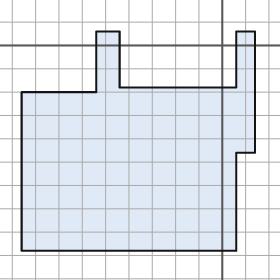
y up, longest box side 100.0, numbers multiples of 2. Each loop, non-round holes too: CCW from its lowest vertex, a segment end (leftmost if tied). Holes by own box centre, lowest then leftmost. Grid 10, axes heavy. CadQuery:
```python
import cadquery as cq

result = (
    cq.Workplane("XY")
    .moveTo(-86.0, -88.0)
    .lineTo(6.0, -88.0)
    .lineTo(6.0, -46.0)
    .lineTo(14.0, -46.0)
    .lineTo(14.0, 6.0)
    .lineTo(6.0, 6.0)
    .lineTo(6.0, -18.0)
    .lineTo(-44.0, -18.0)
    .lineTo(-44.0, 6.0)
    .lineTo(-54.0, 6.0)
    .lineTo(-54.0, -20.0)
    .lineTo(-86.0, -20.0)
    .close()
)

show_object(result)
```